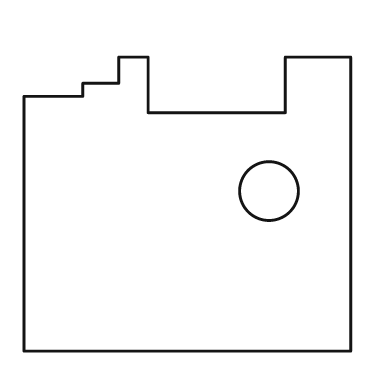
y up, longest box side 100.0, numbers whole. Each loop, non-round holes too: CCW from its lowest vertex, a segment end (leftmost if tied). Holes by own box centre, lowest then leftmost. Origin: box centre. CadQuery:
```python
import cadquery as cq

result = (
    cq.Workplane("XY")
    .moveTo(-50.0, -45.0)
    .lineTo(50.0, -45.0)
    .lineTo(50.0, 45.0)
    .lineTo(30.0, 45.0)
    .lineTo(30.0, 28.0)
    .lineTo(-12.0, 28.0)
    .lineTo(-12.0, 45.0)
    .lineTo(-21.0, 45.0)
    .lineTo(-21.0, 37.0)
    .lineTo(-32.0, 37.0)
    .lineTo(-32.0, 33.0)
    .lineTo(-50.0, 33.0)
    .close()
    .moveTo(25.0, 4.0)
    .circle(9.0)
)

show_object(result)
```